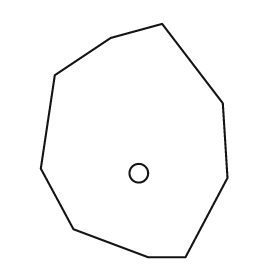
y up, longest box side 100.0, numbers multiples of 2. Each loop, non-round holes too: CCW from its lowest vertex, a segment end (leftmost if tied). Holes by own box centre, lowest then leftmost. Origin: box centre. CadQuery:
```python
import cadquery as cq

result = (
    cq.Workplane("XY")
    .moveTo(6.0, -50.0)
    .lineTo(22.0, -50.0)
    .lineTo(40.0, -16.0)
    .lineTo(38.0, 16.0)
    .lineTo(12.0, 50.0)
    .lineTo(-10.0, 44.0)
    .lineTo(-34.0, 28.0)
    .lineTo(-40.0, -12.0)
    .lineTo(-26.0, -38.0)
    .close()
    .moveTo(2.0, -14.0)
    .circle(4.0)
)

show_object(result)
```